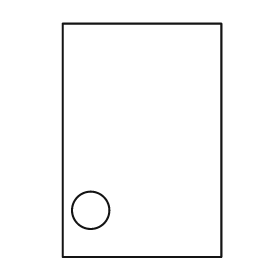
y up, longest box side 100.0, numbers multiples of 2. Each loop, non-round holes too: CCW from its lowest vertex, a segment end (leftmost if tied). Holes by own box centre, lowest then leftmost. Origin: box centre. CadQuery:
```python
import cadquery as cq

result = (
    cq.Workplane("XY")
    .moveTo(-34.0, -50.0)
    .lineTo(34.0, -50.0)
    .lineTo(34.0, 50.0)
    .lineTo(-34.0, 50.0)
    .close()
    .moveTo(-22.0, -30.0)
    .circle(8.0)
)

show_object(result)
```